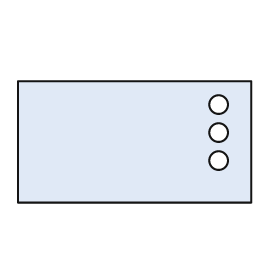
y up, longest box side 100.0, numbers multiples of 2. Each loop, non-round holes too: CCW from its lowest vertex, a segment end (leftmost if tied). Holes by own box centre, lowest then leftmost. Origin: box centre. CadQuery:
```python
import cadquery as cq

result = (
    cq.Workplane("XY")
    .moveTo(-50.0, -26.0)
    .lineTo(50.0, -26.0)
    .lineTo(50.0, 26.0)
    .lineTo(-50.0, 26.0)
    .close()
    .moveTo(36.0, -8.0)
    .circle(4.0)
    .moveTo(36.0, 4.0)
    .circle(4.0)
    .moveTo(36.0, 16.0)
    .circle(4.0)
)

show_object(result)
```